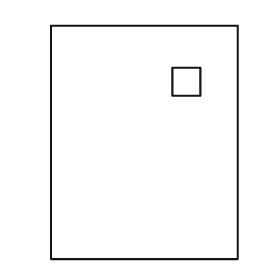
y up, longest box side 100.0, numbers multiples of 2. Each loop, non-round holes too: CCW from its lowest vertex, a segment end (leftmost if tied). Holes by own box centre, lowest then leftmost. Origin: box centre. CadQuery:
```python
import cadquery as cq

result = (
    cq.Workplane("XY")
    .moveTo(-40.0, -50.0)
    .lineTo(40.0, -50.0)
    .lineTo(40.0, 50.0)
    .lineTo(-40.0, 50.0)
    .close()
    .moveTo(12.0, 20.0)
    .lineTo(24.0, 20.0)
    .lineTo(24.0, 32.0)
    .lineTo(12.0, 32.0)
    .close()
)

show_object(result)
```